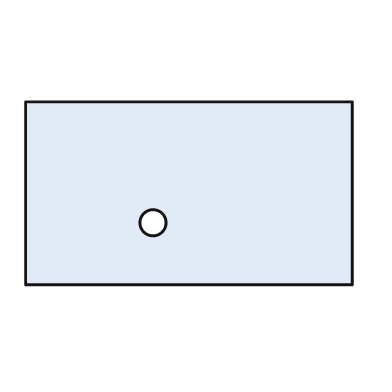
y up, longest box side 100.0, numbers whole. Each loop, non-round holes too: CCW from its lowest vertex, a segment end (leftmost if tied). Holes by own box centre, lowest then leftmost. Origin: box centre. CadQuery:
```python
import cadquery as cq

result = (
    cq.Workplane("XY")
    .moveTo(-50.0, -28.0)
    .lineTo(50.0, -28.0)
    .lineTo(50.0, 28.0)
    .lineTo(-50.0, 28.0)
    .close()
    .moveTo(-11.0, -9.0)
    .circle(4.0)
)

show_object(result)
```